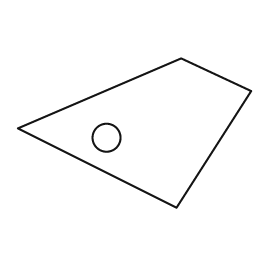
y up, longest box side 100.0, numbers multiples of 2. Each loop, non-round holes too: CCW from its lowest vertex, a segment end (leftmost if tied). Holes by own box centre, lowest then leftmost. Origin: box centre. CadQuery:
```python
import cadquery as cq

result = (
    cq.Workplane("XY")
    .moveTo(18.0, -32.0)
    .lineTo(50.0, 18.0)
    .lineTo(20.0, 32.0)
    .lineTo(-50.0, 2.0)
    .close()
    .moveTo(-12.0, -2.0)
    .circle(6.0)
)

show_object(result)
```